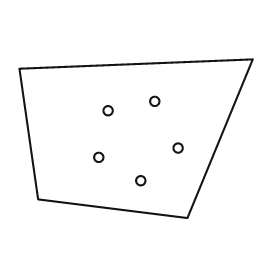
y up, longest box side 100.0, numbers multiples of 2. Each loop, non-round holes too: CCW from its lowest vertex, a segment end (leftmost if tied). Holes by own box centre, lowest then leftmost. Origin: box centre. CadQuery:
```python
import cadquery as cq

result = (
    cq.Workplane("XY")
    .moveTo(22.0, -34.0)
    .lineTo(50.0, 34.0)
    .lineTo(-50.0, 30.0)
    .lineTo(-42.0, -26.0)
    .close()
    .moveTo(2.0, -18.0)
    .circle(2.0)
    .moveTo(-16.0, -8.0)
    .circle(2.0)
    .moveTo(18.0, -4.0)
    .circle(2.0)
    .moveTo(-12.0, 12.0)
    .circle(2.0)
    .moveTo(8.0, 16.0)
    .circle(2.0)
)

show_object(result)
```